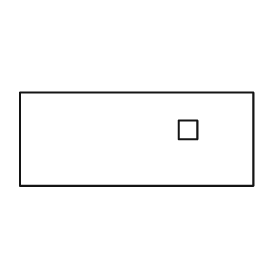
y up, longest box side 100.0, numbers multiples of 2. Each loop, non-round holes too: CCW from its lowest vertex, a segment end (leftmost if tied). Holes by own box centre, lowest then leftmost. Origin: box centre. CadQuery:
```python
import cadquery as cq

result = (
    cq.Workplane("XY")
    .moveTo(-50.0, -20.0)
    .lineTo(50.0, -20.0)
    .lineTo(50.0, 20.0)
    .lineTo(-50.0, 20.0)
    .close()
    .moveTo(18.0, 0.0)
    .lineTo(26.0, 0.0)
    .lineTo(26.0, 8.0)
    .lineTo(18.0, 8.0)
    .close()
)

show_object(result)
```